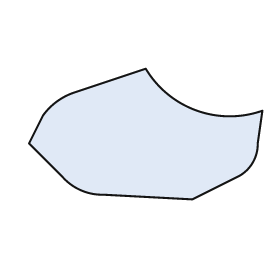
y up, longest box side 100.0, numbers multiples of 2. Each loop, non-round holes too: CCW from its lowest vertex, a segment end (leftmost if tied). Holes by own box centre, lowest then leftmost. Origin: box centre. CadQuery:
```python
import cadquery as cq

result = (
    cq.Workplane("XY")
    .moveTo(20.0, -28.0)
    .lineTo(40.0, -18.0)
    .threePointArc((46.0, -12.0), (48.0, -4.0))
    .lineTo(50.0, 10.0)
    .threePointArc((22.0, 10.0), (0.0, 28.0))
    .lineTo(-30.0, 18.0)
    .threePointArc((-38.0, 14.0), (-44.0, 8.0))
    .lineTo(-50.0, -4.0)
    .lineTo(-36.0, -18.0)
    .threePointArc((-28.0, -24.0), (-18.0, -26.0))
    .close()
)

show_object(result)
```